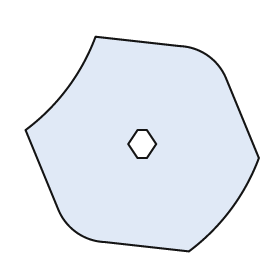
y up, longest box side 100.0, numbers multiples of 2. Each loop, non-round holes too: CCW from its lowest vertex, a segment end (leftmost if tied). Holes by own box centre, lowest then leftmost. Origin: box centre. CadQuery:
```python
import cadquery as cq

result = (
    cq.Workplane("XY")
    .moveTo(20.0, -46.0)
    .threePointArc((38.0, -28.0), (50.0, -6.0))
    .lineTo(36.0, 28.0)
    .threePointArc((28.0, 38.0), (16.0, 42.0))
    .lineTo(-20.0, 46.0)
    .threePointArc((-32.0, 24.0), (-50.0, 6.0))
    .lineTo(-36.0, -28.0)
    .threePointArc((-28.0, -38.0), (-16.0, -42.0))
    .close()
    .moveTo(-2.0, -6.0)
    .lineTo(2.0, -6.0)
    .lineTo(6.0, 0.0)
    .lineTo(2.0, 6.0)
    .lineTo(-2.0, 6.0)
    .lineTo(-6.0, 0.0)
    .close()
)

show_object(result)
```